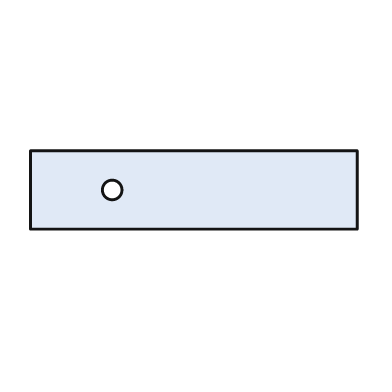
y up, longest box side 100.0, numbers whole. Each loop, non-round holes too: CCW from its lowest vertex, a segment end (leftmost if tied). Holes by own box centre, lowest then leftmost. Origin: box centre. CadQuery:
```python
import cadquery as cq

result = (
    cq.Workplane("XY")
    .moveTo(-50.0, -12.0)
    .lineTo(50.0, -12.0)
    .lineTo(50.0, 12.0)
    .lineTo(-50.0, 12.0)
    .close()
    .moveTo(-25.0, 0.0)
    .circle(3.0)
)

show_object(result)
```